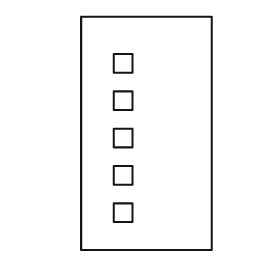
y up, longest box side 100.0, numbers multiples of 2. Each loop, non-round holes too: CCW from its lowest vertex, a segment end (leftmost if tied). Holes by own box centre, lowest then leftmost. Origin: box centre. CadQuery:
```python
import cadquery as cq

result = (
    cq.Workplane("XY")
    .moveTo(-28.0, -50.0)
    .lineTo(28.0, -50.0)
    .lineTo(28.0, 50.0)
    .lineTo(-28.0, 50.0)
    .close()
    .moveTo(-14.0, -38.0)
    .lineTo(-6.0, -38.0)
    .lineTo(-6.0, -30.0)
    .lineTo(-14.0, -30.0)
    .close()
    .moveTo(-14.0, -22.0)
    .lineTo(-6.0, -22.0)
    .lineTo(-6.0, -14.0)
    .lineTo(-14.0, -14.0)
    .close()
    .moveTo(-14.0, -6.0)
    .lineTo(-6.0, -6.0)
    .lineTo(-6.0, 2.0)
    .lineTo(-14.0, 2.0)
    .close()
    .moveTo(-14.0, 10.0)
    .lineTo(-6.0, 10.0)
    .lineTo(-6.0, 18.0)
    .lineTo(-14.0, 18.0)
    .close()
    .moveTo(-14.0, 26.0)
    .lineTo(-6.0, 26.0)
    .lineTo(-6.0, 34.0)
    .lineTo(-14.0, 34.0)
    .close()
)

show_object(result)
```